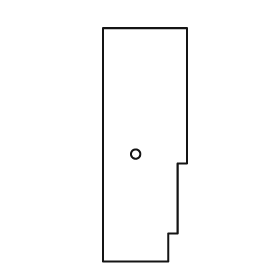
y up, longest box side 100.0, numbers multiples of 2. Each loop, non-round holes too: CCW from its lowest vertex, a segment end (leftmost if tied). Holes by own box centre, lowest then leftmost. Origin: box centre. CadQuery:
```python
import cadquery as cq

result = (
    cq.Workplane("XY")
    .moveTo(-18.0, -50.0)
    .lineTo(10.0, -50.0)
    .lineTo(10.0, -38.0)
    .lineTo(14.0, -38.0)
    .lineTo(14.0, -8.0)
    .lineTo(18.0, -8.0)
    .lineTo(18.0, 50.0)
    .lineTo(-18.0, 50.0)
    .close()
    .moveTo(-4.0, -4.0)
    .circle(2.0)
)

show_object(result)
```